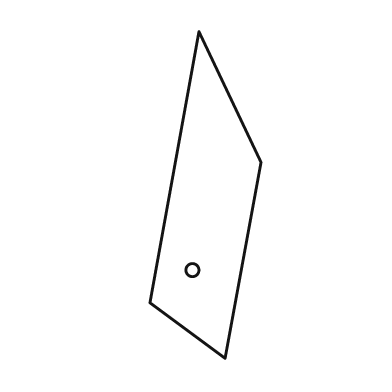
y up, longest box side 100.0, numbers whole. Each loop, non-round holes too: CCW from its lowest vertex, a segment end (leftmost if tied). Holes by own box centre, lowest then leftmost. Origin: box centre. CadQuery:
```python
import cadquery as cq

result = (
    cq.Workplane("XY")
    .moveTo(6.0, -50.0)
    .lineTo(17.0, 10.0)
    .lineTo(-2.0, 50.0)
    .lineTo(-17.0, -33.0)
    .close()
    .moveTo(-4.0, -23.0)
    .circle(2.0)
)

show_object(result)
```